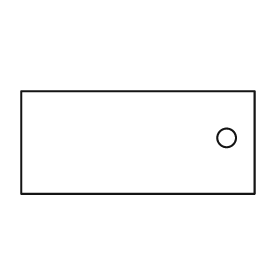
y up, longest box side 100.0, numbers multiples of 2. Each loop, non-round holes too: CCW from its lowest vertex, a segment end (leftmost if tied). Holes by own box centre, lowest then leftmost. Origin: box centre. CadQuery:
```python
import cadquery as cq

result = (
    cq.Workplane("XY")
    .moveTo(-50.0, -22.0)
    .lineTo(50.0, -22.0)
    .lineTo(50.0, 22.0)
    .lineTo(-50.0, 22.0)
    .close()
    .moveTo(38.0, 2.0)
    .circle(4.0)
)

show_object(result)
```